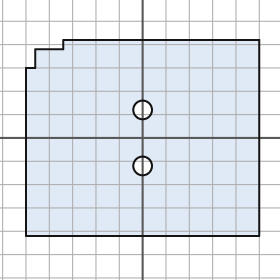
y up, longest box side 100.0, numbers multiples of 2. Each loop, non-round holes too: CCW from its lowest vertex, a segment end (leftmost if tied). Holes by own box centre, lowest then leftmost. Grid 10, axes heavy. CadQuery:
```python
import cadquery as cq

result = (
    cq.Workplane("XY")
    .moveTo(-50.0, -42.0)
    .lineTo(50.0, -42.0)
    .lineTo(50.0, 42.0)
    .lineTo(-34.0, 42.0)
    .lineTo(-34.0, 38.0)
    .lineTo(-46.0, 38.0)
    .lineTo(-46.0, 30.0)
    .lineTo(-50.0, 30.0)
    .close()
    .moveTo(0.0, -12.0)
    .circle(4.0)
    .moveTo(0.0, 12.0)
    .circle(4.0)
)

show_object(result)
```